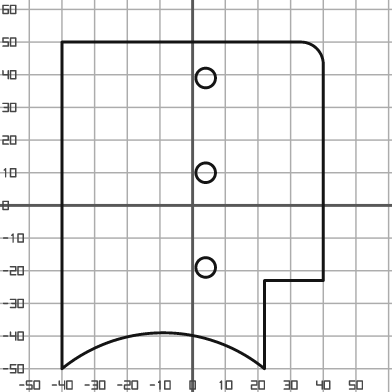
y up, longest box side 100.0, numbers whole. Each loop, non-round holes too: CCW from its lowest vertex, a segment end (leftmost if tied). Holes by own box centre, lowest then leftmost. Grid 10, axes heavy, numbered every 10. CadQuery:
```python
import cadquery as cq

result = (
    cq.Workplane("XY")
    .moveTo(-40.0, -50.0)
    .threePointArc((-9.0, -39.0), (22.0, -50.0))
    .lineTo(22.0, -23.0)
    .lineTo(40.0, -23.0)
    .lineTo(40.0, 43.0)
    .threePointArc((38.0, 48.0), (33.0, 50.0))
    .lineTo(-40.0, 50.0)
    .close()
    .moveTo(4.0, -19.0)
    .circle(3.0)
    .moveTo(4.0, 10.0)
    .circle(3.0)
    .moveTo(4.0, 39.0)
    .circle(3.0)
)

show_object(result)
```